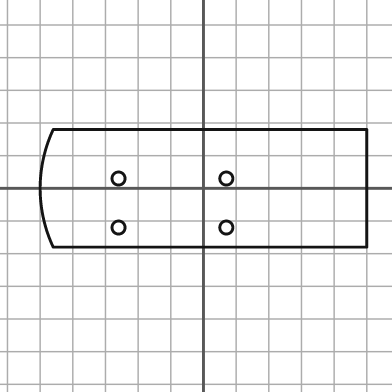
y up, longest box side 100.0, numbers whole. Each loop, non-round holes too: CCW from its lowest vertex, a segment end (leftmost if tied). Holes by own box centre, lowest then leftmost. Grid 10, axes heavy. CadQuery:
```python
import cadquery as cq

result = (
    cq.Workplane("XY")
    .moveTo(-46.0, -18.0)
    .lineTo(50.0, -18.0)
    .lineTo(50.0, 18.0)
    .lineTo(-46.0, 18.0)
    .threePointArc((-50.0, 0.0), (-46.0, -18.0))
    .close()
    .moveTo(-26.0, -12.0)
    .circle(2.0)
    .moveTo(7.0, -12.0)
    .circle(2.0)
    .moveTo(-26.0, 3.0)
    .circle(2.0)
    .moveTo(7.0, 3.0)
    .circle(2.0)
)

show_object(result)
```